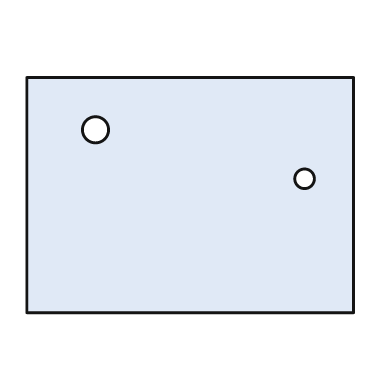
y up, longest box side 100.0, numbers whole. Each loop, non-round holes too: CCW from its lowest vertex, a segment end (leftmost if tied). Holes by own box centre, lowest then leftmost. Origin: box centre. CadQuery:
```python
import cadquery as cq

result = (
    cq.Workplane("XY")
    .moveTo(-50.0, -36.0)
    .lineTo(50.0, -36.0)
    .lineTo(50.0, 36.0)
    .lineTo(-50.0, 36.0)
    .close()
    .moveTo(35.0, 5.0)
    .circle(3.0)
    .moveTo(-29.0, 20.0)
    .circle(4.0)
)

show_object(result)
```